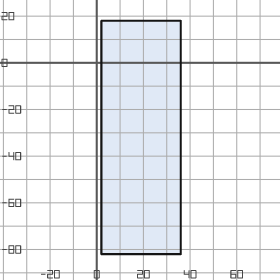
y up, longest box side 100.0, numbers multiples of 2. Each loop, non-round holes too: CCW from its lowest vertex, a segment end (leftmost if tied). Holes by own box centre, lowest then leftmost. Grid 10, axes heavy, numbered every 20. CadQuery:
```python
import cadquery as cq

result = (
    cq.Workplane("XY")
    .moveTo(2.0, -82.0)
    .lineTo(36.0, -82.0)
    .lineTo(36.0, 18.0)
    .lineTo(2.0, 18.0)
    .close()
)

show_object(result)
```